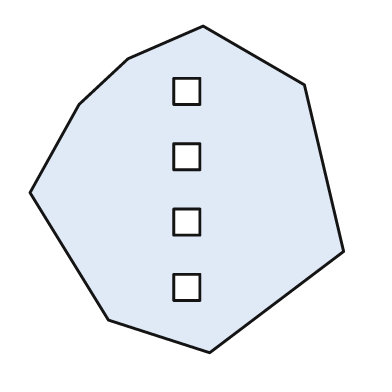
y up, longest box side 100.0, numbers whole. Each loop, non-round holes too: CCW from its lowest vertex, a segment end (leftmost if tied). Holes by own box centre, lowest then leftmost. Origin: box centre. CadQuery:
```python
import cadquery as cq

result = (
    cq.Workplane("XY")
    .moveTo(7.0, -50.0)
    .lineTo(48.0, -19.0)
    .lineTo(36.0, 32.0)
    .lineTo(5.0, 50.0)
    .lineTo(-18.0, 40.0)
    .lineTo(-33.0, 26.0)
    .lineTo(-48.0, -1.0)
    .lineTo(-24.0, -40.0)
    .close()
    .moveTo(-4.0, -34.0)
    .lineTo(4.0, -34.0)
    .lineTo(4.0, -26.0)
    .lineTo(-4.0, -26.0)
    .close()
    .moveTo(-4.0, -14.0)
    .lineTo(4.0, -14.0)
    .lineTo(4.0, -6.0)
    .lineTo(-4.0, -6.0)
    .close()
    .moveTo(-4.0, 6.0)
    .lineTo(4.0, 6.0)
    .lineTo(4.0, 14.0)
    .lineTo(-4.0, 14.0)
    .close()
    .moveTo(-4.0, 26.0)
    .lineTo(4.0, 26.0)
    .lineTo(4.0, 34.0)
    .lineTo(-4.0, 34.0)
    .close()
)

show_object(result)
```